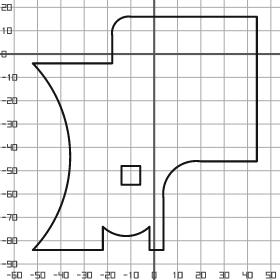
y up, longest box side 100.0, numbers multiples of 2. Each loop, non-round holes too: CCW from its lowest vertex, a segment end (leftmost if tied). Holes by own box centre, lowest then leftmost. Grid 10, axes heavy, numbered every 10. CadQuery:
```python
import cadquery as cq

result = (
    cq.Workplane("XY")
    .moveTo(-52.0, -84.0)
    .lineTo(-22.0, -84.0)
    .lineTo(-22.0, -74.0)
    .threePointArc((-12.0, -78.0), (-2.0, -74.0))
    .lineTo(-2.0, -84.0)
    .lineTo(4.0, -84.0)
    .lineTo(4.0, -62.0)
    .threePointArc((8.0, -50.0), (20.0, -46.0))
    .lineTo(44.0, -46.0)
    .lineTo(44.0, 16.0)
    .lineTo(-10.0, 16.0)
    .threePointArc((-16.0, 14.0), (-18.0, 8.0))
    .lineTo(-18.0, -4.0)
    .lineTo(-52.0, -4.0)
    .threePointArc((-36.0, -44.0), (-52.0, -84.0))
    .close()
    .moveTo(-14.0, -56.0)
    .lineTo(-6.0, -56.0)
    .lineTo(-6.0, -48.0)
    .lineTo(-14.0, -48.0)
    .close()
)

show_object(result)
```